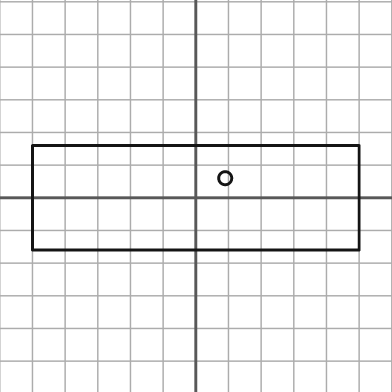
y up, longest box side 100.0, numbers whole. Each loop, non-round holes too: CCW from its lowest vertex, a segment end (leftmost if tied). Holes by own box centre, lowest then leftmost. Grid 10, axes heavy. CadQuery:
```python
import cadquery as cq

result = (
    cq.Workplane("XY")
    .moveTo(-50.0, -16.0)
    .lineTo(50.0, -16.0)
    .lineTo(50.0, 16.0)
    .lineTo(-50.0, 16.0)
    .close()
    .moveTo(9.0, 6.0)
    .circle(2.0)
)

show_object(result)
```